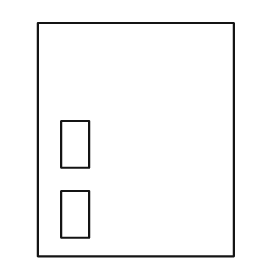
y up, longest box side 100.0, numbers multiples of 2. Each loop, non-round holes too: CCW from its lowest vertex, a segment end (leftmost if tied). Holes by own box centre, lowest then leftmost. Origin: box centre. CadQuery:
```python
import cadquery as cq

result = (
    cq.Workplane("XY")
    .moveTo(-42.0, -50.0)
    .lineTo(42.0, -50.0)
    .lineTo(42.0, 50.0)
    .lineTo(-42.0, 50.0)
    .close()
    .moveTo(-32.0, -42.0)
    .lineTo(-20.0, -42.0)
    .lineTo(-20.0, -22.0)
    .lineTo(-32.0, -22.0)
    .close()
    .moveTo(-32.0, -12.0)
    .lineTo(-20.0, -12.0)
    .lineTo(-20.0, 8.0)
    .lineTo(-32.0, 8.0)
    .close()
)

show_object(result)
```